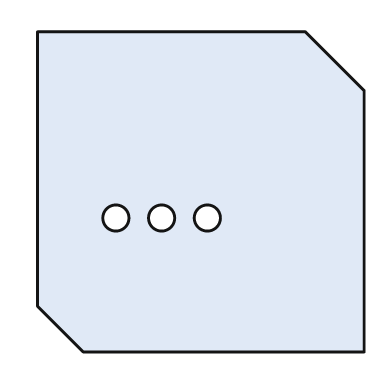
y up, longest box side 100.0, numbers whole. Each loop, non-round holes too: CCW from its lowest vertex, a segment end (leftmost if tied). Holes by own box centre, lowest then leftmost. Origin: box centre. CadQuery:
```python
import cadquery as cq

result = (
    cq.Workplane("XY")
    .moveTo(-36.0, -49.0)
    .lineTo(50.0, -49.0)
    .lineTo(50.0, 31.0)
    .lineTo(32.0, 49.0)
    .lineTo(-50.0, 49.0)
    .lineTo(-50.0, -35.0)
    .close()
    .moveTo(-26.0, -8.0)
    .circle(4.0)
    .moveTo(-12.0, -8.0)
    .circle(4.0)
    .moveTo(2.0, -8.0)
    .circle(4.0)
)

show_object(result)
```